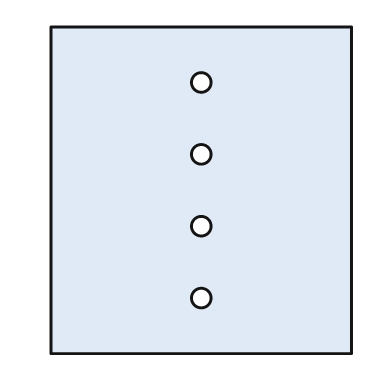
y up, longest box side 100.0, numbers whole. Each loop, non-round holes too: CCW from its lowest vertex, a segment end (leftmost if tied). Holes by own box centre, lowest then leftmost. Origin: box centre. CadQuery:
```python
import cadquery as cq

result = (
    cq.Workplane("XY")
    .moveTo(-46.0, -50.0)
    .lineTo(46.0, -50.0)
    .lineTo(46.0, 50.0)
    .lineTo(-46.0, 50.0)
    .close()
    .moveTo(0.0, -33.0)
    .circle(3.0)
    .moveTo(0.0, -11.0)
    .circle(3.0)
    .moveTo(0.0, 11.0)
    .circle(3.0)
    .moveTo(0.0, 33.0)
    .circle(3.0)
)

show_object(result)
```